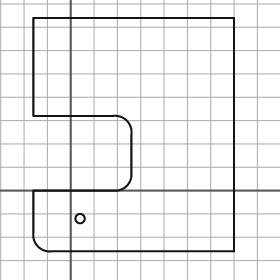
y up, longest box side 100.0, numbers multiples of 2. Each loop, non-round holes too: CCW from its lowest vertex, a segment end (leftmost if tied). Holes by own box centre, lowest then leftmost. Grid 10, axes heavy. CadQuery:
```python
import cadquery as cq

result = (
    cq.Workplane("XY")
    .moveTo(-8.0, -26.0)
    .lineTo(70.0, -26.0)
    .lineTo(70.0, 74.0)
    .lineTo(-16.0, 74.0)
    .lineTo(-16.0, 32.0)
    .lineTo(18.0, 32.0)
    .threePointArc((24.0, 30.0), (26.0, 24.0))
    .lineTo(26.0, 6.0)
    .threePointArc((24.0, 2.0), (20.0, 0.0))
    .lineTo(-16.0, 0.0)
    .lineTo(-16.0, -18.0)
    .threePointArc((-14.0, -24.0), (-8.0, -26.0))
    .close()
    .moveTo(4.0, -12.0)
    .circle(2.0)
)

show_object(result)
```